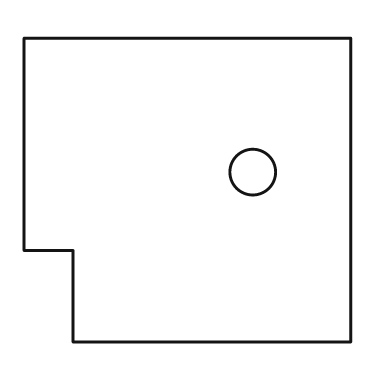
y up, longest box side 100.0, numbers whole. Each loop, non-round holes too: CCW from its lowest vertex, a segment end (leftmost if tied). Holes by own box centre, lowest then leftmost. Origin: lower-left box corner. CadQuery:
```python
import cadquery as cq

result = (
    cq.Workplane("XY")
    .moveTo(15.0, 0.0)
    .lineTo(100.0, 0.0)
    .lineTo(100.0, 93.0)
    .lineTo(0.0, 93.0)
    .lineTo(0.0, 28.0)
    .lineTo(15.0, 28.0)
    .close()
    .moveTo(70.0, 52.0)
    .circle(7.0)
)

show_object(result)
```